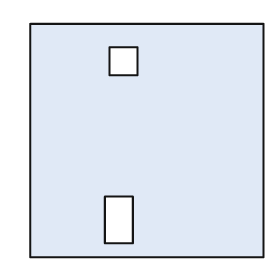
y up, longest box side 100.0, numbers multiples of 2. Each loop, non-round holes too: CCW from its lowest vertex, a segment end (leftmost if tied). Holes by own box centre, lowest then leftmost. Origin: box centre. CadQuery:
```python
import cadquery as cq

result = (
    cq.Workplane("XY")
    .moveTo(-50.0, -50.0)
    .lineTo(50.0, -50.0)
    .lineTo(50.0, 50.0)
    .lineTo(-50.0, 50.0)
    .close()
    .moveTo(-18.0, -44.0)
    .lineTo(-6.0, -44.0)
    .lineTo(-6.0, -24.0)
    .lineTo(-18.0, -24.0)
    .close()
    .moveTo(-16.0, 28.0)
    .lineTo(-4.0, 28.0)
    .lineTo(-4.0, 40.0)
    .lineTo(-16.0, 40.0)
    .close()
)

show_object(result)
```